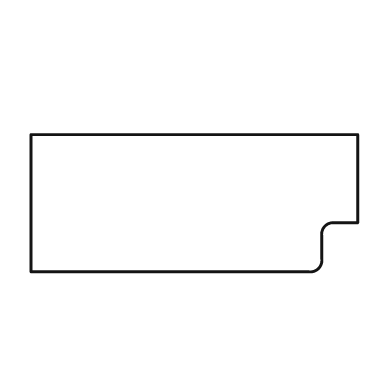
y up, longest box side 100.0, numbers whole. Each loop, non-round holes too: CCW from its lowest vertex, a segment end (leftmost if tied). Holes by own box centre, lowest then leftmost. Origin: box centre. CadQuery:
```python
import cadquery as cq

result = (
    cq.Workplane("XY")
    .moveTo(-50.0, -21.0)
    .lineTo(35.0, -21.0)
    .threePointArc((38.0, -20.0), (39.0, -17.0))
    .lineTo(39.0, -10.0)
    .threePointArc((40.0, -7.0), (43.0, -6.0))
    .lineTo(50.0, -6.0)
    .lineTo(50.0, 21.0)
    .lineTo(-50.0, 21.0)
    .close()
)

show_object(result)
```